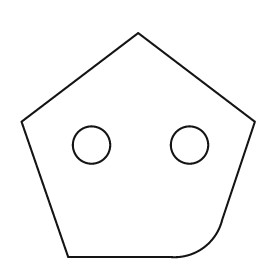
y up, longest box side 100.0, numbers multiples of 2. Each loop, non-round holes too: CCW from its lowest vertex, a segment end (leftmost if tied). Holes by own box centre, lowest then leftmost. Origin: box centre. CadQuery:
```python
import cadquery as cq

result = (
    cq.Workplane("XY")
    .moveTo(-30.0, -48.0)
    .lineTo(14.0, -48.0)
    .threePointArc((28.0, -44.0), (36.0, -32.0))
    .lineTo(50.0, 10.0)
    .lineTo(0.0, 48.0)
    .lineTo(-50.0, 10.0)
    .close()
    .moveTo(-20.0, 0.0)
    .circle(8.0)
    .moveTo(22.0, 0.0)
    .circle(8.0)
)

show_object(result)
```